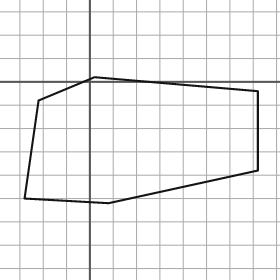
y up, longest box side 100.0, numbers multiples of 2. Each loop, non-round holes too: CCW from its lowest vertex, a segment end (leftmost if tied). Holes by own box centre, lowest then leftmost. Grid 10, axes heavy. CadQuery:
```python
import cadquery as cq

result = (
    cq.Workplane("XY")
    .moveTo(8.0, -52.0)
    .lineTo(72.0, -38.0)
    .lineTo(72.0, -4.0)
    .lineTo(2.0, 2.0)
    .lineTo(-22.0, -8.0)
    .lineTo(-28.0, -50.0)
    .close()
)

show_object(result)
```